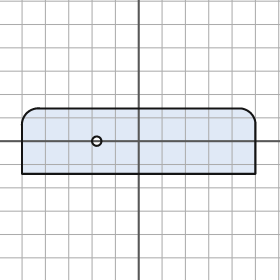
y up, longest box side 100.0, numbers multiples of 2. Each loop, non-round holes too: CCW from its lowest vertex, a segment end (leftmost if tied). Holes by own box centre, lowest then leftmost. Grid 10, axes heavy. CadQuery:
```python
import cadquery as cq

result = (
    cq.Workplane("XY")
    .moveTo(-50.0, -14.0)
    .lineTo(50.0, -14.0)
    .lineTo(50.0, 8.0)
    .threePointArc((48.0, 12.0), (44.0, 14.0))
    .lineTo(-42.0, 14.0)
    .threePointArc((-48.0, 12.0), (-50.0, 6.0))
    .close()
    .moveTo(-18.0, 0.0)
    .circle(2.0)
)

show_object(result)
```